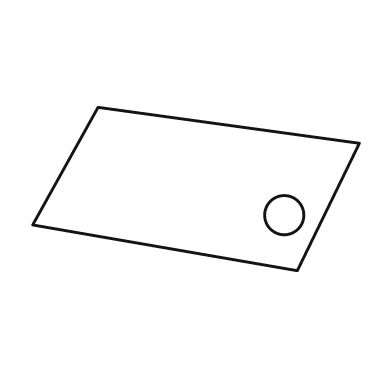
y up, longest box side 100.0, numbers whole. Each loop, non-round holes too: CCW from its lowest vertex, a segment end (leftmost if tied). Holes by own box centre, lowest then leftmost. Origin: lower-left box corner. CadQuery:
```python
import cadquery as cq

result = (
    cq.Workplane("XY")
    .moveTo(81.0, 0.0)
    .lineTo(100.0, 39.0)
    .lineTo(20.0, 50.0)
    .lineTo(0.0, 14.0)
    .close()
    .moveTo(77.0, 17.0)
    .circle(6.0)
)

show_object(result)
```